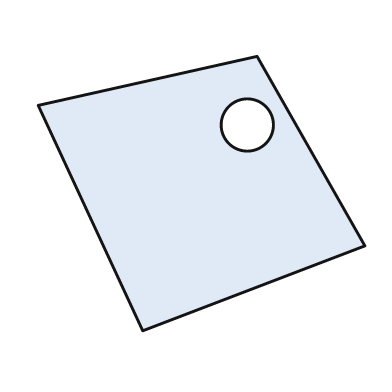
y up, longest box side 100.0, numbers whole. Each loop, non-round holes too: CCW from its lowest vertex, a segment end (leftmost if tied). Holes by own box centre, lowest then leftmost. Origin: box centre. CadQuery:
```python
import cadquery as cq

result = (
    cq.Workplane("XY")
    .moveTo(-18.0, -42.0)
    .lineTo(50.0, -16.0)
    .lineTo(17.0, 42.0)
    .lineTo(-50.0, 27.0)
    .close()
    .moveTo(14.0, 21.0)
    .circle(8.0)
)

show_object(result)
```